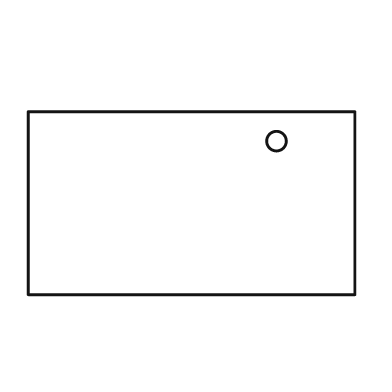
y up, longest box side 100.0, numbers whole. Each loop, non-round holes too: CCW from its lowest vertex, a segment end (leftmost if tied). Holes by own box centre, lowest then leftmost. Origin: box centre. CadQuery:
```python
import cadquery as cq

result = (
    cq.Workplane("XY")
    .moveTo(-50.0, -28.0)
    .lineTo(50.0, -28.0)
    .lineTo(50.0, 28.0)
    .lineTo(-50.0, 28.0)
    .close()
    .moveTo(26.0, 19.0)
    .circle(3.0)
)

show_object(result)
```